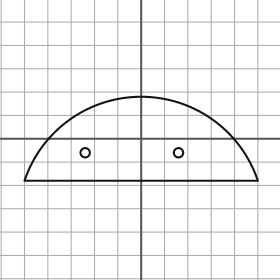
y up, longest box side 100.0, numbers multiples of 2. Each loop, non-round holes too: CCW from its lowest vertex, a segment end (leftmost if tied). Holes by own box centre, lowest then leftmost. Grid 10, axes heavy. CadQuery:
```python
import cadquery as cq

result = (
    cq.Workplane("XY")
    .moveTo(-50.0, -18.0)
    .lineTo(50.0, -18.0)
    .threePointArc((0.0, 18.0), (-50.0, -18.0))
    .close()
    .moveTo(-24.0, -6.0)
    .circle(2.0)
    .moveTo(16.0, -6.0)
    .circle(2.0)
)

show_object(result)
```